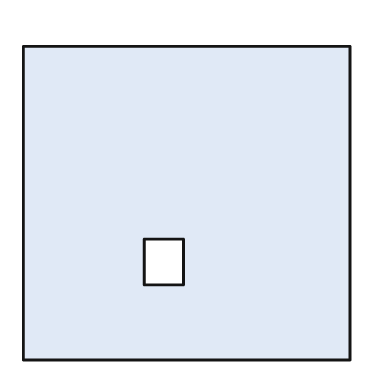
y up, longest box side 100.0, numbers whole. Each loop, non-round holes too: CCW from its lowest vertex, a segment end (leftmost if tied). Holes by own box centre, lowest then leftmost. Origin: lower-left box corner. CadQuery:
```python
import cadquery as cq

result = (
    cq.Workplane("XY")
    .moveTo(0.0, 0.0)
    .lineTo(100.0, 0.0)
    .lineTo(100.0, 96.0)
    .lineTo(0.0, 96.0)
    .close()
    .moveTo(37.0, 23.0)
    .lineTo(49.0, 23.0)
    .lineTo(49.0, 37.0)
    .lineTo(37.0, 37.0)
    .close()
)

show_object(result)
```